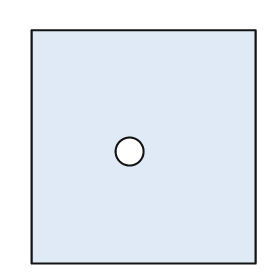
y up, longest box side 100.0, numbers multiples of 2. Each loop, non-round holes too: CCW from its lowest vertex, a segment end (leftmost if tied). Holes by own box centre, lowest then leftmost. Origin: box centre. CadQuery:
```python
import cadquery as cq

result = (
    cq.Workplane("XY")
    .moveTo(-48.0, -50.0)
    .lineTo(48.0, -50.0)
    .lineTo(48.0, 50.0)
    .lineTo(-48.0, 50.0)
    .close()
    .moveTo(-6.0, -2.0)
    .circle(6.0)
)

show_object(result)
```